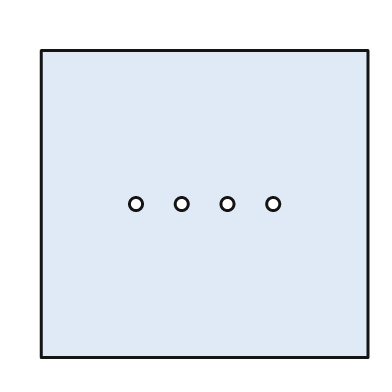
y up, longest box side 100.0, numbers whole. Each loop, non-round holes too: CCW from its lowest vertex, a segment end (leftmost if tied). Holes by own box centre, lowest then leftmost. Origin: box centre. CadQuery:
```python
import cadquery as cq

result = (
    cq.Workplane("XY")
    .moveTo(-50.0, -47.0)
    .lineTo(50.0, -47.0)
    .lineTo(50.0, 47.0)
    .lineTo(-50.0, 47.0)
    .close()
    .moveTo(-21.0, 0.0)
    .circle(2.0)
    .moveTo(-7.0, 0.0)
    .circle(2.0)
    .moveTo(7.0, 0.0)
    .circle(2.0)
    .moveTo(21.0, 0.0)
    .circle(2.0)
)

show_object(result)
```